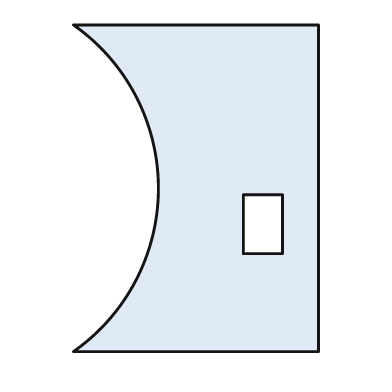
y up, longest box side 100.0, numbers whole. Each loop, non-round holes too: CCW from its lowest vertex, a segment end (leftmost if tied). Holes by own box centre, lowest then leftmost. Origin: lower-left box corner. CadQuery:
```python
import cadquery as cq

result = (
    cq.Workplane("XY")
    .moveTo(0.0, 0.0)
    .lineTo(75.0, 0.0)
    .lineTo(75.0, 100.0)
    .lineTo(0.0, 100.0)
    .threePointArc((26.0, 50.0), (0.0, 0.0))
    .close()
    .moveTo(52.0, 30.0)
    .lineTo(64.0, 30.0)
    .lineTo(64.0, 48.0)
    .lineTo(52.0, 48.0)
    .close()
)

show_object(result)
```